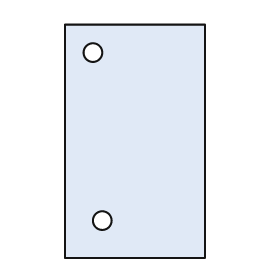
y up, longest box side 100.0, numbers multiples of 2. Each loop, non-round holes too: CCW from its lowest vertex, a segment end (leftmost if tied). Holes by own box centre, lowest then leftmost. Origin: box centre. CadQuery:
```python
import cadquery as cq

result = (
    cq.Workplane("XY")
    .moveTo(-30.0, -50.0)
    .lineTo(30.0, -50.0)
    .lineTo(30.0, 50.0)
    .lineTo(-30.0, 50.0)
    .close()
    .moveTo(-14.0, -34.0)
    .circle(4.0)
    .moveTo(-18.0, 38.0)
    .circle(4.0)
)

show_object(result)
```